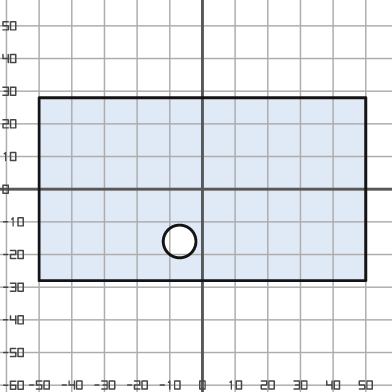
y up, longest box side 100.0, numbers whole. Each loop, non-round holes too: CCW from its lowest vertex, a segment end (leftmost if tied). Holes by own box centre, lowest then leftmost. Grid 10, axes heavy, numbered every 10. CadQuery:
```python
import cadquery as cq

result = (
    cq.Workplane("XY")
    .moveTo(-50.0, -28.0)
    .lineTo(50.0, -28.0)
    .lineTo(50.0, 28.0)
    .lineTo(-50.0, 28.0)
    .close()
    .moveTo(-7.0, -16.0)
    .circle(5.0)
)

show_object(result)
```